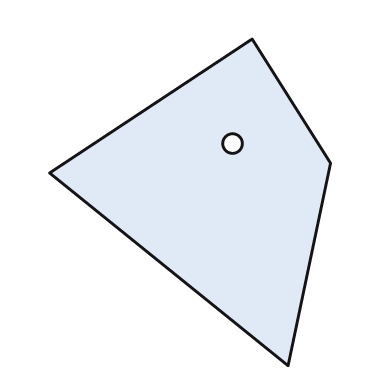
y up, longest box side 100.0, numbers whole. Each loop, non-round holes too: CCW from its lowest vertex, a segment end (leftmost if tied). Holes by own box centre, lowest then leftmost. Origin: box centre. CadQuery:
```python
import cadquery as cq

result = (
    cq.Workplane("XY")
    .moveTo(30.0, -50.0)
    .lineTo(43.0, 12.0)
    .lineTo(19.0, 50.0)
    .lineTo(-43.0, 9.0)
    .close()
    .moveTo(13.0, 18.0)
    .circle(3.0)
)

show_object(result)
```